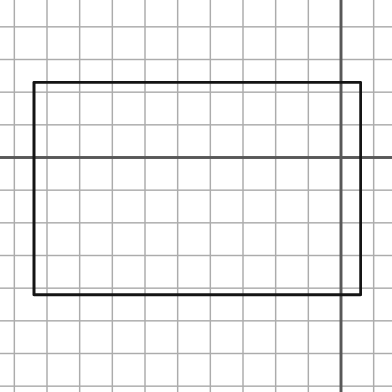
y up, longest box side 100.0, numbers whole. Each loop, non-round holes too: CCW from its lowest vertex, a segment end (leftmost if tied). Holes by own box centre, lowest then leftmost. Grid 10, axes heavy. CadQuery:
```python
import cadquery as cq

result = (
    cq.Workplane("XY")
    .moveTo(-94.0, -42.0)
    .lineTo(6.0, -42.0)
    .lineTo(6.0, 23.0)
    .lineTo(-94.0, 23.0)
    .close()
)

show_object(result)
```